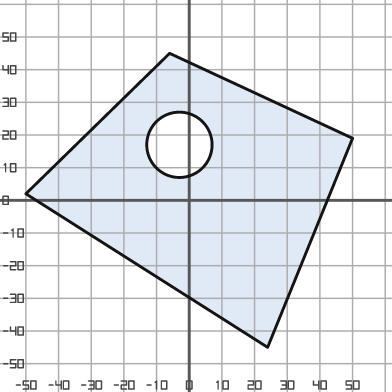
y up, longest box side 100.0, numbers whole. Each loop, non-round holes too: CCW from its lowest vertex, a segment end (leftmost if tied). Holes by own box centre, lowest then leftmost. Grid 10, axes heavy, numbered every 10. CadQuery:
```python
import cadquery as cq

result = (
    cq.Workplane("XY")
    .moveTo(24.0, -45.0)
    .lineTo(50.0, 19.0)
    .lineTo(-6.0, 45.0)
    .lineTo(-50.0, 2.0)
    .close()
    .moveTo(-3.0, 17.0)
    .circle(10.0)
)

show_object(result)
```